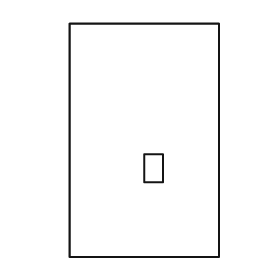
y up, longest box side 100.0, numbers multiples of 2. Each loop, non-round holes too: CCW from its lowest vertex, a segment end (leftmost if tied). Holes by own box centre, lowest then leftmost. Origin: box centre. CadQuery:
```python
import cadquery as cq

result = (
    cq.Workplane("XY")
    .moveTo(-32.0, -50.0)
    .lineTo(32.0, -50.0)
    .lineTo(32.0, 50.0)
    .lineTo(-32.0, 50.0)
    .close()
    .moveTo(0.0, -18.0)
    .lineTo(8.0, -18.0)
    .lineTo(8.0, -6.0)
    .lineTo(0.0, -6.0)
    .close()
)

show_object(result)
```